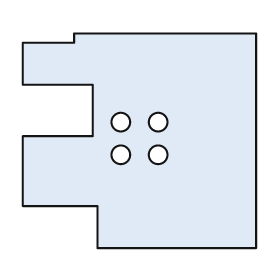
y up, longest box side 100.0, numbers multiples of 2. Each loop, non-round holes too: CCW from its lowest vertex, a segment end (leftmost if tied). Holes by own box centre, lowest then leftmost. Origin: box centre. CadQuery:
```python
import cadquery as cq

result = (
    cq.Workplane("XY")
    .moveTo(-18.0, -46.0)
    .lineTo(50.0, -46.0)
    .lineTo(50.0, 46.0)
    .lineTo(-28.0, 46.0)
    .lineTo(-28.0, 42.0)
    .lineTo(-50.0, 42.0)
    .lineTo(-50.0, 24.0)
    .lineTo(-20.0, 24.0)
    .lineTo(-20.0, 2.0)
    .lineTo(-50.0, 2.0)
    .lineTo(-50.0, -28.0)
    .lineTo(-18.0, -28.0)
    .close()
    .moveTo(-8.0, -6.0)
    .circle(4.0)
    .moveTo(8.0, -6.0)
    .circle(4.0)
    .moveTo(-8.0, 8.0)
    .circle(4.0)
    .moveTo(8.0, 8.0)
    .circle(4.0)
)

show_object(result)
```